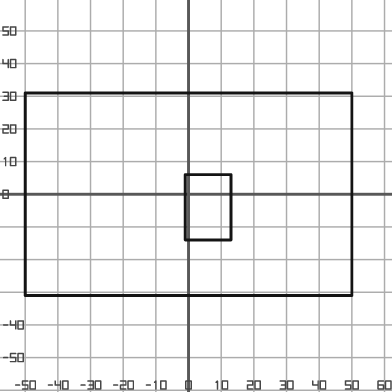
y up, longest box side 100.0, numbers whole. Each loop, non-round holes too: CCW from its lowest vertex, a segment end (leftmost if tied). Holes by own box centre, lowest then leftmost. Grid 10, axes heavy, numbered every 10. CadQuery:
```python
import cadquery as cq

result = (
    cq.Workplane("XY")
    .moveTo(-50.0, -31.0)
    .lineTo(50.0, -31.0)
    .lineTo(50.0, 31.0)
    .lineTo(-50.0, 31.0)
    .close()
    .moveTo(-1.0, -14.0)
    .lineTo(13.0, -14.0)
    .lineTo(13.0, 6.0)
    .lineTo(-1.0, 6.0)
    .close()
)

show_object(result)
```